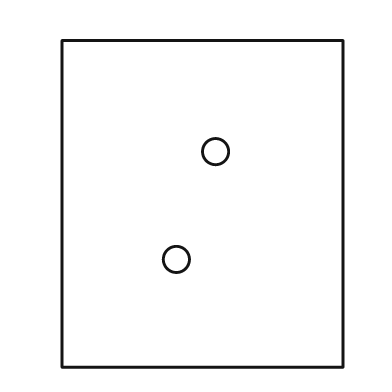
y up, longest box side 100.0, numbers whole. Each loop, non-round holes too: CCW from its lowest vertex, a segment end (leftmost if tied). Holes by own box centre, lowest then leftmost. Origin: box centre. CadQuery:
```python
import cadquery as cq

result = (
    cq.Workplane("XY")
    .moveTo(-43.0, -50.0)
    .lineTo(43.0, -50.0)
    .lineTo(43.0, 50.0)
    .lineTo(-43.0, 50.0)
    .close()
    .moveTo(-8.0, -17.0)
    .circle(4.0)
    .moveTo(4.0, 16.0)
    .circle(4.0)
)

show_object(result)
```